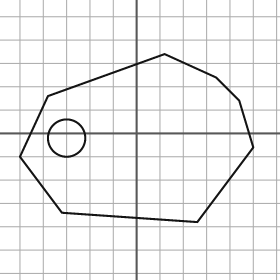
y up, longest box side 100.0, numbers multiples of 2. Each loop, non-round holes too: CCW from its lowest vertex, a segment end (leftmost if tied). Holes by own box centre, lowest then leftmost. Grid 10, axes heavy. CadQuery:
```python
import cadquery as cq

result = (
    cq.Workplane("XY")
    .moveTo(26.0, -38.0)
    .lineTo(50.0, -6.0)
    .lineTo(44.0, 14.0)
    .lineTo(34.0, 24.0)
    .lineTo(12.0, 34.0)
    .lineTo(-38.0, 16.0)
    .lineTo(-50.0, -10.0)
    .lineTo(-32.0, -34.0)
    .close()
    .moveTo(-30.0, -2.0)
    .circle(8.0)
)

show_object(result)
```